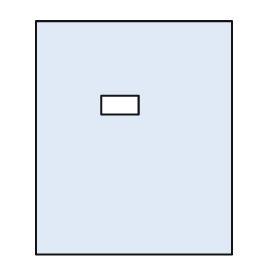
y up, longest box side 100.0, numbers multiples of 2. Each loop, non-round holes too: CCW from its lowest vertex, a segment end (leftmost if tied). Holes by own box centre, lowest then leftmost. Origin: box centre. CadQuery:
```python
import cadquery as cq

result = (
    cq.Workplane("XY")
    .moveTo(-42.0, -50.0)
    .lineTo(42.0, -50.0)
    .lineTo(42.0, 50.0)
    .lineTo(-42.0, 50.0)
    .close()
    .moveTo(-14.0, 10.0)
    .lineTo(2.0, 10.0)
    .lineTo(2.0, 18.0)
    .lineTo(-14.0, 18.0)
    .close()
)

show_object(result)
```